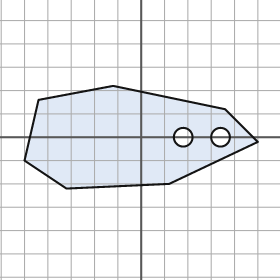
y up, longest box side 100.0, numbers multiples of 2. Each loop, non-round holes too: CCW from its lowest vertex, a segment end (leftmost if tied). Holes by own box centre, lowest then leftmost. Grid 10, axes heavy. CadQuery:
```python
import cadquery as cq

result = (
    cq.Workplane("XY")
    .moveTo(-32.0, -22.0)
    .lineTo(12.0, -20.0)
    .lineTo(50.0, -2.0)
    .lineTo(36.0, 12.0)
    .lineTo(-12.0, 22.0)
    .lineTo(-44.0, 16.0)
    .lineTo(-50.0, -10.0)
    .close()
    .moveTo(18.0, 0.0)
    .circle(4.0)
    .moveTo(34.0, 0.0)
    .circle(4.0)
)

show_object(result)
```